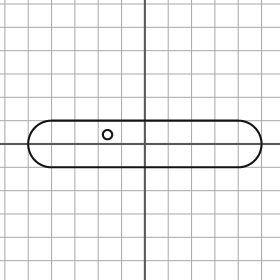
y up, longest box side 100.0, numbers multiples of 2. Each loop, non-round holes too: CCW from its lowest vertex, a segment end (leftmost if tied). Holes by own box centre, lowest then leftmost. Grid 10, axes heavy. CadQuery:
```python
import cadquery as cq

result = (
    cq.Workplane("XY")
    .moveTo(-40.0, -10.0)
    .lineTo(40.0, -10.0)
    .threePointArc((50.0, 0.0), (40.0, 10.0))
    .lineTo(-40.0, 10.0)
    .threePointArc((-50.0, 0.0), (-40.0, -10.0))
    .close()
    .moveTo(-16.0, 4.0)
    .circle(2.0)
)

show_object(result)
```